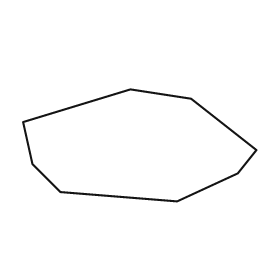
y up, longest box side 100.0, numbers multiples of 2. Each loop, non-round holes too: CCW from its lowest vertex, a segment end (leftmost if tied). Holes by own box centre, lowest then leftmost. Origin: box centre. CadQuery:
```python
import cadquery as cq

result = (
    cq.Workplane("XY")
    .moveTo(16.0, -24.0)
    .lineTo(42.0, -12.0)
    .lineTo(50.0, -2.0)
    .lineTo(22.0, 20.0)
    .lineTo(-4.0, 24.0)
    .lineTo(-50.0, 10.0)
    .lineTo(-46.0, -8.0)
    .lineTo(-34.0, -20.0)
    .close()
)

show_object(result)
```